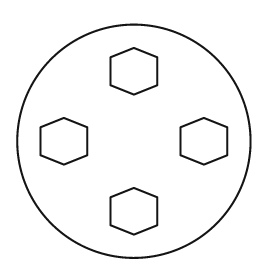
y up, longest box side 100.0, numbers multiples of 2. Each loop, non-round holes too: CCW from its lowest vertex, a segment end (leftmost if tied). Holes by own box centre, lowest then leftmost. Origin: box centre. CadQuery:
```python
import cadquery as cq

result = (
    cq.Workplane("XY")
    .moveTo(0.0, 0.0)
    .circle(50.0)
    .moveTo(0.0, -40.0)
    .lineTo(10.0, -36.0)
    .lineTo(10.0, -24.0)
    .lineTo(0.0, -20.0)
    .lineTo(-10.0, -24.0)
    .lineTo(-10.0, -36.0)
    .close()
    .moveTo(-30.0, -10.0)
    .lineTo(-20.0, -6.0)
    .lineTo(-20.0, 6.0)
    .lineTo(-30.0, 10.0)
    .lineTo(-40.0, 6.0)
    .lineTo(-40.0, -6.0)
    .close()
    .moveTo(30.0, -10.0)
    .lineTo(40.0, -6.0)
    .lineTo(40.0, 6.0)
    .lineTo(30.0, 10.0)
    .lineTo(20.0, 6.0)
    .lineTo(20.0, -6.0)
    .close()
    .moveTo(0.0, 20.0)
    .lineTo(10.0, 24.0)
    .lineTo(10.0, 36.0)
    .lineTo(0.0, 40.0)
    .lineTo(-10.0, 36.0)
    .lineTo(-10.0, 24.0)
    .close()
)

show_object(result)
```